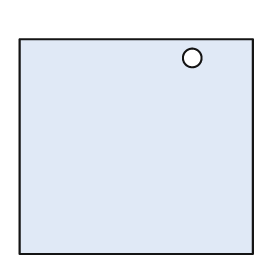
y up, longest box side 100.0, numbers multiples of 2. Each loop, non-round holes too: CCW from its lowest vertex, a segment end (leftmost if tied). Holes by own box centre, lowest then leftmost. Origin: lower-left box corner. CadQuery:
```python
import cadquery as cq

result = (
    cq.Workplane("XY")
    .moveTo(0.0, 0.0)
    .lineTo(100.0, 0.0)
    .lineTo(100.0, 92.0)
    .lineTo(0.0, 92.0)
    .close()
    .moveTo(74.0, 84.0)
    .circle(4.0)
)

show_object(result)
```